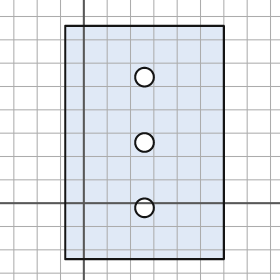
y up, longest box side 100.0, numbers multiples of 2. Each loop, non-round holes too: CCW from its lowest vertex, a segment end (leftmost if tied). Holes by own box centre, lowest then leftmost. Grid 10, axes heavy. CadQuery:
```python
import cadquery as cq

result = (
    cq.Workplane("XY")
    .moveTo(-8.0, -24.0)
    .lineTo(60.0, -24.0)
    .lineTo(60.0, 76.0)
    .lineTo(-8.0, 76.0)
    .close()
    .moveTo(26.0, -2.0)
    .circle(4.0)
    .moveTo(26.0, 26.0)
    .circle(4.0)
    .moveTo(26.0, 54.0)
    .circle(4.0)
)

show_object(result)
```